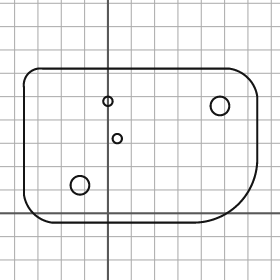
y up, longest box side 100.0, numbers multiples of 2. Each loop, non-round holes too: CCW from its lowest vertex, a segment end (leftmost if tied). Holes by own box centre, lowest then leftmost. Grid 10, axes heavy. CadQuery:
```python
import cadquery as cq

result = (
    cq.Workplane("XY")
    .moveTo(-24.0, -4.0)
    .lineTo(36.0, -4.0)
    .threePointArc((56.0, 4.0), (64.0, 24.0))
    .lineTo(64.0, 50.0)
    .threePointArc((60.0, 58.0), (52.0, 62.0))
    .lineTo(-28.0, 62.0)
    .threePointArc((-34.0, 60.0), (-36.0, 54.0))
    .lineTo(-36.0, 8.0)
    .threePointArc((-32.0, 0.0), (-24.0, -4.0))
    .close()
    .moveTo(-12.0, 12.0)
    .circle(4.0)
    .moveTo(4.0, 32.0)
    .circle(2.0)
    .moveTo(48.0, 46.0)
    .circle(4.0)
    .moveTo(0.0, 48.0)
    .circle(2.0)
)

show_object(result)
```